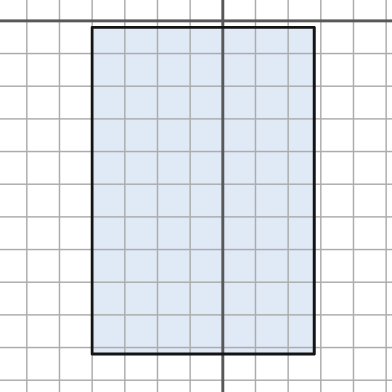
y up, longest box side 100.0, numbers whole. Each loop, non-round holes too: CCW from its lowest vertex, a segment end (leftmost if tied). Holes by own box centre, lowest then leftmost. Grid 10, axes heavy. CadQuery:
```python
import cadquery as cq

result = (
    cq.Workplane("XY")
    .moveTo(-40.0, -102.0)
    .lineTo(28.0, -102.0)
    .lineTo(28.0, -2.0)
    .lineTo(-40.0, -2.0)
    .close()
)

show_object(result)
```